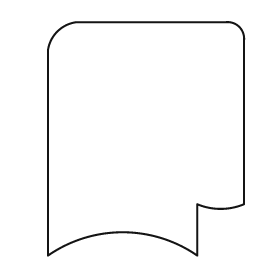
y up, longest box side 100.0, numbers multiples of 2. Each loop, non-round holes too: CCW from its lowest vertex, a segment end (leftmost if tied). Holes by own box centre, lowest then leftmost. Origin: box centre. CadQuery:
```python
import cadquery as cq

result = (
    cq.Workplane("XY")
    .moveTo(-42.0, -50.0)
    .threePointArc((-10.0, -40.0), (22.0, -50.0))
    .lineTo(22.0, -28.0)
    .threePointArc((32.0, -30.0), (42.0, -28.0))
    .lineTo(42.0, 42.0)
    .threePointArc((40.0, 48.0), (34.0, 50.0))
    .lineTo(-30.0, 50.0)
    .threePointArc((-38.0, 46.0), (-42.0, 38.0))
    .close()
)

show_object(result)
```